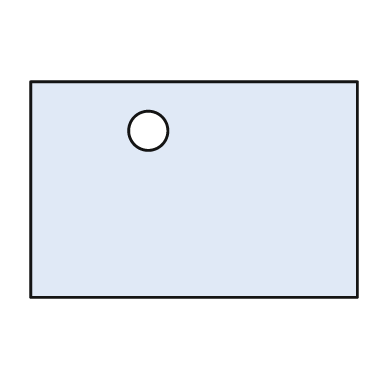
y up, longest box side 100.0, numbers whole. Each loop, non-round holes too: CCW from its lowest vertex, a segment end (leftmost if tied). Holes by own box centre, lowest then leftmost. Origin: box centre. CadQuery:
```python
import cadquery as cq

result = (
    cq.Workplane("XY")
    .moveTo(-50.0, -33.0)
    .lineTo(50.0, -33.0)
    .lineTo(50.0, 33.0)
    .lineTo(-50.0, 33.0)
    .close()
    .moveTo(-14.0, 18.0)
    .circle(6.0)
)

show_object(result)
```